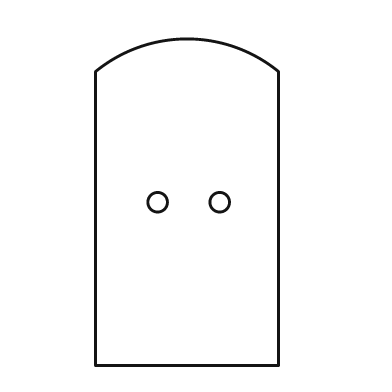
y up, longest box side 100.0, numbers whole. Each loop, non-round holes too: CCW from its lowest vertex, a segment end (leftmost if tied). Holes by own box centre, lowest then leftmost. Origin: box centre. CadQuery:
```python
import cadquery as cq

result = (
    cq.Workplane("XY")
    .moveTo(-28.0, -50.0)
    .lineTo(28.0, -50.0)
    .lineTo(28.0, 40.0)
    .threePointArc((0.0, 50.0), (-28.0, 40.0))
    .close()
    .moveTo(-9.0, 0.0)
    .circle(3.0)
    .moveTo(10.0, 0.0)
    .circle(3.0)
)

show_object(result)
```